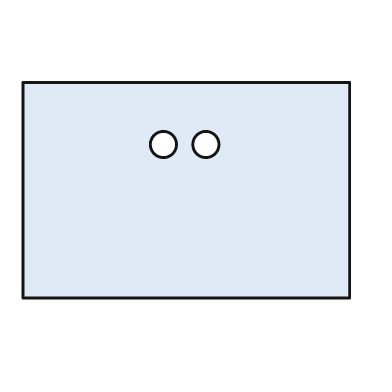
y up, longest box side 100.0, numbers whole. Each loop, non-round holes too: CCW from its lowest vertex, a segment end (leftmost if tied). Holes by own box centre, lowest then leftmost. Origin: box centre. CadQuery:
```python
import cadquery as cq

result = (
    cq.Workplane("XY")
    .moveTo(-50.0, -33.0)
    .lineTo(50.0, -33.0)
    .lineTo(50.0, 33.0)
    .lineTo(-50.0, 33.0)
    .close()
    .moveTo(-7.0, 14.0)
    .circle(4.0)
    .moveTo(6.0, 14.0)
    .circle(4.0)
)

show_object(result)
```